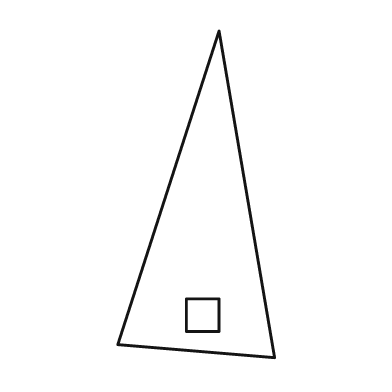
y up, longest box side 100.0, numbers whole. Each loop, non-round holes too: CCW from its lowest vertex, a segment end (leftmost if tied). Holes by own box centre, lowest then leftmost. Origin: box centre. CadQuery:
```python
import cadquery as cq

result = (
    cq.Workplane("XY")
    .moveTo(24.0, -50.0)
    .lineTo(7.0, 50.0)
    .lineTo(-24.0, -46.0)
    .close()
    .moveTo(-3.0, -42.0)
    .lineTo(7.0, -42.0)
    .lineTo(7.0, -32.0)
    .lineTo(-3.0, -32.0)
    .close()
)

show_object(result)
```